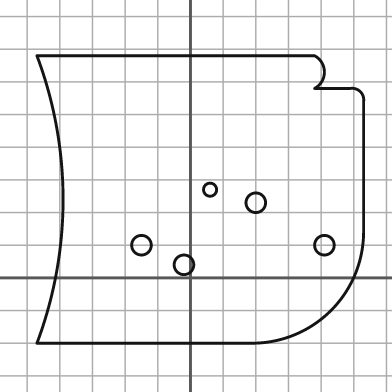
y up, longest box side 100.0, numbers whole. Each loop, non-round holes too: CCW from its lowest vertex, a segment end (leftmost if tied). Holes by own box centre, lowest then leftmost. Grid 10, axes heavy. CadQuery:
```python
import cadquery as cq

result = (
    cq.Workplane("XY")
    .moveTo(-47.0, -20.0)
    .lineTo(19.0, -20.0)
    .threePointArc((43.0, -10.0), (53.0, 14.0))
    .lineTo(53.0, 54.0)
    .threePointArc((52.0, 57.0), (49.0, 58.0))
    .lineTo(38.0, 58.0)
    .threePointArc((41.0, 63.0), (38.0, 68.0))
    .lineTo(-47.0, 68.0)
    .threePointArc((-39.0, 24.0), (-47.0, -20.0))
    .close()
    .moveTo(-2.0, 4.0)
    .circle(3.0)
    .moveTo(-15.0, 10.0)
    .circle(3.0)
    .moveTo(41.0, 10.0)
    .circle(3.0)
    .moveTo(20.0, 23.0)
    .circle(3.0)
    .moveTo(6.0, 27.0)
    .circle(2.0)
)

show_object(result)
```